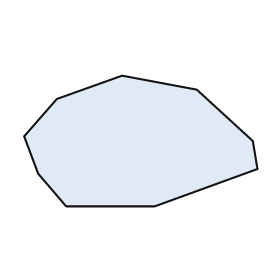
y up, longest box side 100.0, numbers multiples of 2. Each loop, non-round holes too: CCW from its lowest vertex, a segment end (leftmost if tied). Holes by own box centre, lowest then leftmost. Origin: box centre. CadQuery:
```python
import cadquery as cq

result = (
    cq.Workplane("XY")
    .moveTo(-32.0, -28.0)
    .lineTo(6.0, -28.0)
    .lineTo(50.0, -12.0)
    .lineTo(48.0, 0.0)
    .lineTo(24.0, 22.0)
    .lineTo(-8.0, 28.0)
    .lineTo(-36.0, 18.0)
    .lineTo(-50.0, 2.0)
    .lineTo(-44.0, -14.0)
    .close()
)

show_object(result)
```